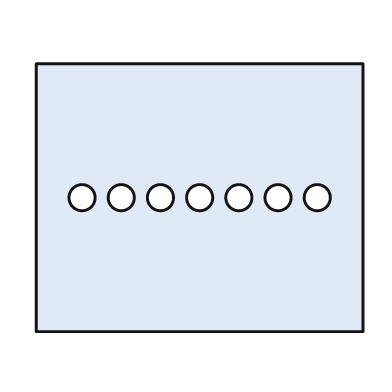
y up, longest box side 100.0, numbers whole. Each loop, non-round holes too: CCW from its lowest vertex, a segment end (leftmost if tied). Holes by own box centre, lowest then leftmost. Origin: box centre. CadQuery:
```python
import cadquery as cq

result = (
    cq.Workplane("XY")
    .moveTo(-50.0, -41.0)
    .lineTo(50.0, -41.0)
    .lineTo(50.0, 41.0)
    .lineTo(-50.0, 41.0)
    .close()
    .moveTo(-36.0, 0.0)
    .circle(4.0)
    .moveTo(-24.0, 0.0)
    .circle(4.0)
    .moveTo(-12.0, 0.0)
    .circle(4.0)
    .moveTo(0.0, 0.0)
    .circle(4.0)
    .moveTo(12.0, 0.0)
    .circle(4.0)
    .moveTo(24.0, 0.0)
    .circle(4.0)
    .moveTo(36.0, 0.0)
    .circle(4.0)
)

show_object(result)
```